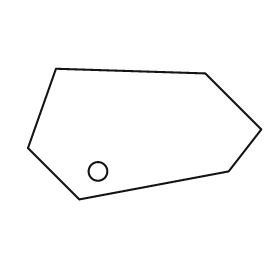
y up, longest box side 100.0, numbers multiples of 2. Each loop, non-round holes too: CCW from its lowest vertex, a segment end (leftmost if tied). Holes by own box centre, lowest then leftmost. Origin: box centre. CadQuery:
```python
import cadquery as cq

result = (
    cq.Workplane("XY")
    .moveTo(-28.0, -28.0)
    .lineTo(36.0, -16.0)
    .lineTo(50.0, 2.0)
    .lineTo(26.0, 26.0)
    .lineTo(-38.0, 28.0)
    .lineTo(-50.0, -6.0)
    .close()
    .moveTo(-20.0, -16.0)
    .circle(4.0)
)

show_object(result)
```